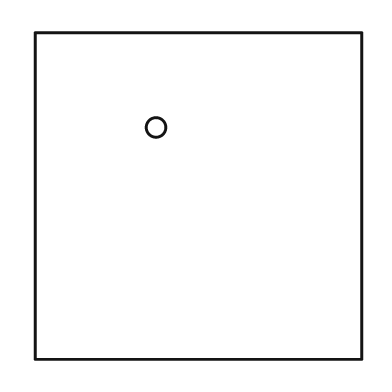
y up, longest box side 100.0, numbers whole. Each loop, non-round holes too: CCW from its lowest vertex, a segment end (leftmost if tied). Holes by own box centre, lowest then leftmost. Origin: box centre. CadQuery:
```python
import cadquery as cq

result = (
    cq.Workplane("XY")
    .moveTo(-50.0, -50.0)
    .lineTo(50.0, -50.0)
    .lineTo(50.0, 50.0)
    .lineTo(-50.0, 50.0)
    .close()
    .moveTo(-13.0, 21.0)
    .circle(3.0)
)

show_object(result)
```